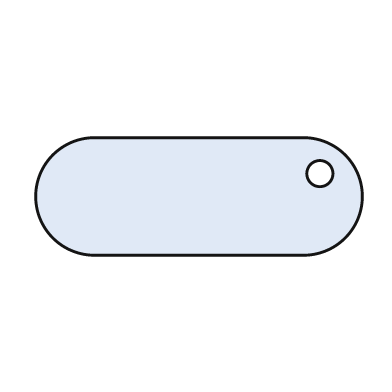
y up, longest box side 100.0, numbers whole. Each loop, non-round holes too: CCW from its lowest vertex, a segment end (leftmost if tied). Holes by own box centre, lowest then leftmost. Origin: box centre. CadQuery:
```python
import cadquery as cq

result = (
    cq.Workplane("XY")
    .moveTo(-32.0, -18.0)
    .lineTo(32.0, -18.0)
    .threePointArc((50.0, 0.0), (32.0, 18.0))
    .lineTo(-32.0, 18.0)
    .threePointArc((-50.0, 0.0), (-32.0, -18.0))
    .close()
    .moveTo(37.0, 7.0)
    .circle(4.0)
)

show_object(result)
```